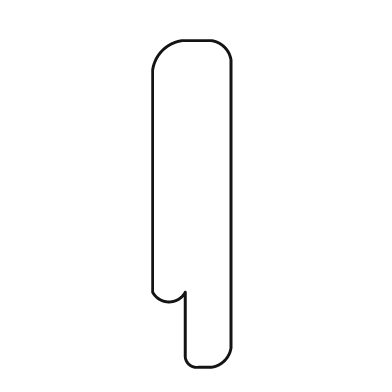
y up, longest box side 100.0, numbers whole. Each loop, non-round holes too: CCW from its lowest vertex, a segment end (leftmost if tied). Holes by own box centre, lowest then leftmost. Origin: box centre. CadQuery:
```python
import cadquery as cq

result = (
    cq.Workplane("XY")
    .moveTo(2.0, -50.0)
    .lineTo(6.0, -50.0)
    .threePointArc((10.0, -48.0), (12.0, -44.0))
    .lineTo(12.0, 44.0)
    .threePointArc((10.0, 48.0), (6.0, 50.0))
    .lineTo(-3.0, 50.0)
    .threePointArc((-9.0, 47.0), (-12.0, 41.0))
    .lineTo(-12.0, -27.0)
    .threePointArc((-7.0, -30.0), (-2.0, -27.0))
    .lineTo(-2.0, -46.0)
    .threePointArc((-1.0, -49.0), (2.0, -50.0))
    .close()
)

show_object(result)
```